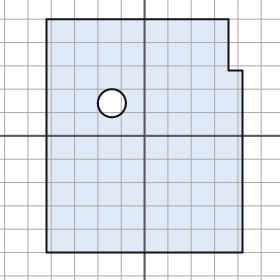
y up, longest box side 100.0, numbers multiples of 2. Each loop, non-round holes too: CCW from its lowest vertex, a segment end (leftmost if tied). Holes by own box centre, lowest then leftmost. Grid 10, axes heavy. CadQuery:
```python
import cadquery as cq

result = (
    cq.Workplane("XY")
    .moveTo(-42.0, -50.0)
    .lineTo(42.0, -50.0)
    .lineTo(42.0, 28.0)
    .lineTo(36.0, 28.0)
    .lineTo(36.0, 50.0)
    .lineTo(-42.0, 50.0)
    .close()
    .moveTo(-14.0, 14.0)
    .circle(6.0)
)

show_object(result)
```